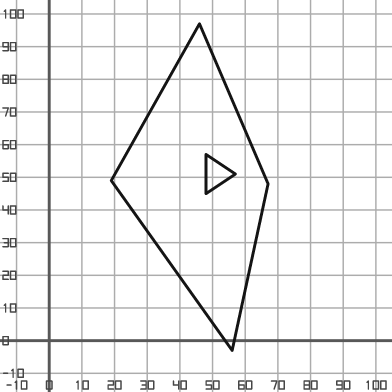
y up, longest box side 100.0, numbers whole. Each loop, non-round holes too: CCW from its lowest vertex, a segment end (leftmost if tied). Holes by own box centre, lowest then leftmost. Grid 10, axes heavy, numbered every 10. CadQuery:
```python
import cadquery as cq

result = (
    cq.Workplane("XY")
    .moveTo(56.0, -3.0)
    .lineTo(67.0, 48.0)
    .lineTo(46.0, 97.0)
    .lineTo(19.0, 49.0)
    .close()
    .moveTo(48.0, 45.0)
    .lineTo(57.0, 51.0)
    .lineTo(48.0, 57.0)
    .close()
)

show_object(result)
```